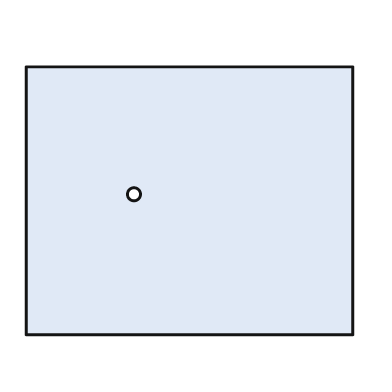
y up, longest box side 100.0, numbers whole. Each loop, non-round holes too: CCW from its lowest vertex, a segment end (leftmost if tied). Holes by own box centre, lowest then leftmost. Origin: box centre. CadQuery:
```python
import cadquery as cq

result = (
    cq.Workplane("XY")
    .moveTo(-50.0, -41.0)
    .lineTo(50.0, -41.0)
    .lineTo(50.0, 41.0)
    .lineTo(-50.0, 41.0)
    .close()
    .moveTo(-17.0, 2.0)
    .circle(2.0)
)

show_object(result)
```